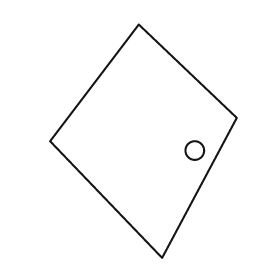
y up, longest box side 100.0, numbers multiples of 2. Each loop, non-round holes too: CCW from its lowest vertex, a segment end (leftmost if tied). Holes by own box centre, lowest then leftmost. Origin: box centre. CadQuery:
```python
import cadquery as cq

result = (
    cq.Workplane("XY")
    .moveTo(8.0, -50.0)
    .lineTo(40.0, 10.0)
    .lineTo(-2.0, 50.0)
    .lineTo(-40.0, 0.0)
    .close()
    .moveTo(22.0, -4.0)
    .circle(4.0)
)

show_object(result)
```